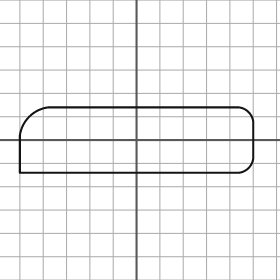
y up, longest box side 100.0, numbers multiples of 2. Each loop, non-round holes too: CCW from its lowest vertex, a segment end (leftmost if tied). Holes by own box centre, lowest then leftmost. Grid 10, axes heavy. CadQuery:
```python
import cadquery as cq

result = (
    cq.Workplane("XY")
    .moveTo(-50.0, -14.0)
    .lineTo(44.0, -14.0)
    .threePointArc((48.0, -12.0), (50.0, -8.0))
    .lineTo(50.0, 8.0)
    .threePointArc((48.0, 12.0), (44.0, 14.0))
    .lineTo(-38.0, 14.0)
    .threePointArc((-46.0, 10.0), (-50.0, 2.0))
    .close()
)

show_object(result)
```